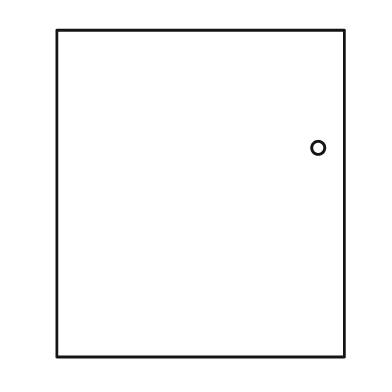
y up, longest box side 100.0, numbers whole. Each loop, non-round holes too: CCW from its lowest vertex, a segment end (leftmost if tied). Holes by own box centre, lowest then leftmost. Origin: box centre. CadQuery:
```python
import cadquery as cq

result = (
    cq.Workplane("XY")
    .moveTo(-44.0, -50.0)
    .lineTo(44.0, -50.0)
    .lineTo(44.0, 50.0)
    .lineTo(-44.0, 50.0)
    .close()
    .moveTo(36.0, 14.0)
    .circle(2.0)
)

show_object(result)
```